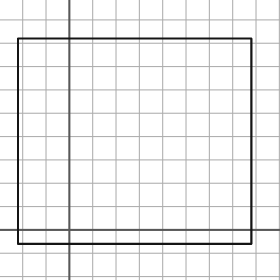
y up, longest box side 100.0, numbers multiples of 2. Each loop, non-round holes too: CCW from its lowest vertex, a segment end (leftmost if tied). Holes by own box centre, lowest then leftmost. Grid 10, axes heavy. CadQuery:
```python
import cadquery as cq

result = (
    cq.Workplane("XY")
    .moveTo(-22.0, -6.0)
    .lineTo(78.0, -6.0)
    .lineTo(78.0, 82.0)
    .lineTo(-22.0, 82.0)
    .close()
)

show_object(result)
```